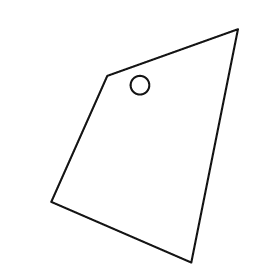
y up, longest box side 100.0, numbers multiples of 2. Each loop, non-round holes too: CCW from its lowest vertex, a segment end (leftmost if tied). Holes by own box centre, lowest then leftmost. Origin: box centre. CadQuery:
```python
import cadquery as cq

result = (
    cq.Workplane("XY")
    .moveTo(20.0, -50.0)
    .lineTo(40.0, 50.0)
    .lineTo(-16.0, 30.0)
    .lineTo(-40.0, -24.0)
    .close()
    .moveTo(-2.0, 26.0)
    .circle(4.0)
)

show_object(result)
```